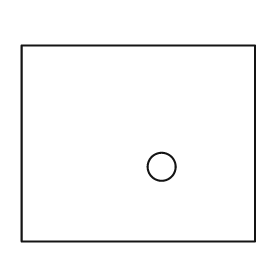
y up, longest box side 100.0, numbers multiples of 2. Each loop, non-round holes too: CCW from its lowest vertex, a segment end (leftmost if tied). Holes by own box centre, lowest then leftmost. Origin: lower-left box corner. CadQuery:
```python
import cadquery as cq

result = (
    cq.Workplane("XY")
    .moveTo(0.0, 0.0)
    .lineTo(100.0, 0.0)
    .lineTo(100.0, 84.0)
    .lineTo(0.0, 84.0)
    .close()
    .moveTo(60.0, 32.0)
    .circle(6.0)
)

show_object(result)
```